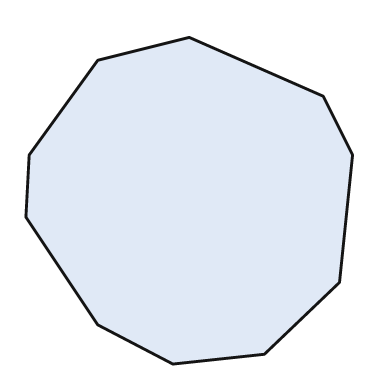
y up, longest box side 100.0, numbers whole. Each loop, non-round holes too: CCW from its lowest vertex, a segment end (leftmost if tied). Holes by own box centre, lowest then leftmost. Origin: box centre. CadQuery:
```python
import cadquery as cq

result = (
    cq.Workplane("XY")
    .moveTo(-5.0, -50.0)
    .lineTo(23.0, -47.0)
    .lineTo(46.0, -25.0)
    .lineTo(50.0, 14.0)
    .lineTo(41.0, 32.0)
    .lineTo(0.0, 50.0)
    .lineTo(-28.0, 43.0)
    .lineTo(-49.0, 14.0)
    .lineTo(-50.0, -5.0)
    .lineTo(-28.0, -38.0)
    .close()
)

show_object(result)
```